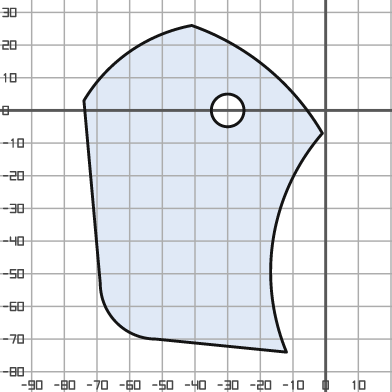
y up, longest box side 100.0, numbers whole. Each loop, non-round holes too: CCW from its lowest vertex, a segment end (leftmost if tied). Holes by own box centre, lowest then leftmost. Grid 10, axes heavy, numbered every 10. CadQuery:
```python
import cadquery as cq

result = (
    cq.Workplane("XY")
    .moveTo(-12.0, -74.0)
    .threePointArc((-16.0, -39.0), (-1.0, -7.0))
    .threePointArc((-18.0, 13.0), (-41.0, 26.0))
    .threePointArc((-60.0, 18.0), (-74.0, 3.0))
    .lineTo(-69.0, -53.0)
    .threePointArc((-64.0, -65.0), (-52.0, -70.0))
    .close()
    .moveTo(-30.0, 0.0)
    .circle(5.0)
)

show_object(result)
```